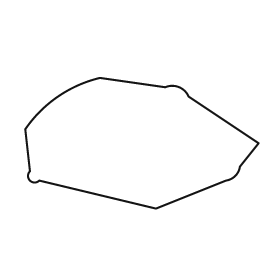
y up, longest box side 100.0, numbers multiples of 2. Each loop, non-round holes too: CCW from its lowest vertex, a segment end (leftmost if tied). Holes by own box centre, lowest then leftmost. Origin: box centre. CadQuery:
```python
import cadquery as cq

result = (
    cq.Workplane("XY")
    .moveTo(6.0, -28.0)
    .lineTo(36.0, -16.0)
    .threePointArc((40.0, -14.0), (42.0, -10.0))
    .lineTo(50.0, 0.0)
    .lineTo(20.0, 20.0)
    .threePointArc((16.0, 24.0), (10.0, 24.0))
    .lineTo(-18.0, 28.0)
    .threePointArc((-36.0, 20.0), (-50.0, 6.0))
    .lineTo(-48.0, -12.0)
    .threePointArc((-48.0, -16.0), (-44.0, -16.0))
    .close()
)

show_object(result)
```